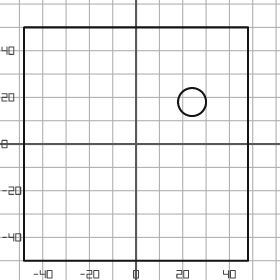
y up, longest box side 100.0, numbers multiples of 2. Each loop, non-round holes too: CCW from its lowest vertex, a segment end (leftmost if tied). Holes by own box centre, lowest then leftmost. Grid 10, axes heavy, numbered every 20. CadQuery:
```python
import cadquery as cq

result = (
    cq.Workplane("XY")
    .moveTo(-48.0, -50.0)
    .lineTo(48.0, -50.0)
    .lineTo(48.0, 50.0)
    .lineTo(-48.0, 50.0)
    .close()
    .moveTo(24.0, 18.0)
    .circle(6.0)
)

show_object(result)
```